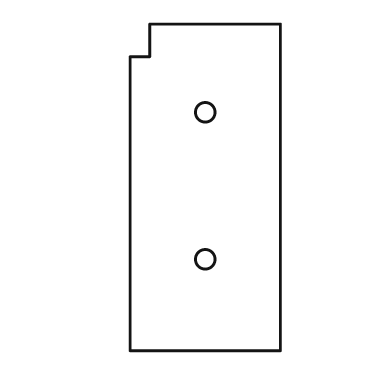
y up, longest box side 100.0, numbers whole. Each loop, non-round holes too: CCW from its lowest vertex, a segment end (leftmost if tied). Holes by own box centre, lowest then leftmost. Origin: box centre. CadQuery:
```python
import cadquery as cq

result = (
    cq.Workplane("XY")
    .moveTo(-23.0, -50.0)
    .lineTo(23.0, -50.0)
    .lineTo(23.0, 50.0)
    .lineTo(-17.0, 50.0)
    .lineTo(-17.0, 40.0)
    .lineTo(-23.0, 40.0)
    .close()
    .moveTo(0.0, -22.0)
    .circle(3.0)
    .moveTo(0.0, 23.0)
    .circle(3.0)
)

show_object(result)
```